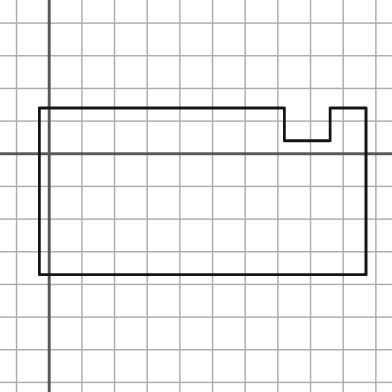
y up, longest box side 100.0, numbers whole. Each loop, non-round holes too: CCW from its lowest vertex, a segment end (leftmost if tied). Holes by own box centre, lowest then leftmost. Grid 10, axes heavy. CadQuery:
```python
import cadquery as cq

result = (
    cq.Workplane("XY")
    .moveTo(-3.0, -37.0)
    .lineTo(97.0, -37.0)
    .lineTo(97.0, 14.0)
    .lineTo(86.0, 14.0)
    .lineTo(86.0, 4.0)
    .lineTo(72.0, 4.0)
    .lineTo(72.0, 14.0)
    .lineTo(-3.0, 14.0)
    .close()
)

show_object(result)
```